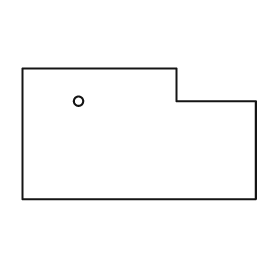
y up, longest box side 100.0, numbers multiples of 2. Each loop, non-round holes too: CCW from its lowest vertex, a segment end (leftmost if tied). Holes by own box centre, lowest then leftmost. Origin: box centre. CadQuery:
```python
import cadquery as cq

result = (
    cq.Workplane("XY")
    .moveTo(-50.0, -28.0)
    .lineTo(50.0, -28.0)
    .lineTo(50.0, 14.0)
    .lineTo(16.0, 14.0)
    .lineTo(16.0, 28.0)
    .lineTo(-50.0, 28.0)
    .close()
    .moveTo(-26.0, 14.0)
    .circle(2.0)
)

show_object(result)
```